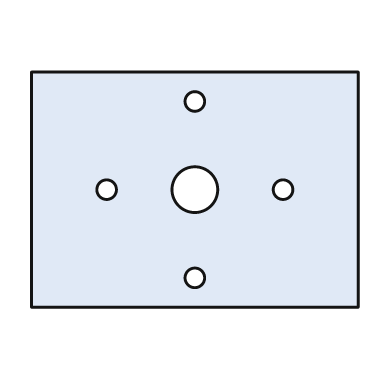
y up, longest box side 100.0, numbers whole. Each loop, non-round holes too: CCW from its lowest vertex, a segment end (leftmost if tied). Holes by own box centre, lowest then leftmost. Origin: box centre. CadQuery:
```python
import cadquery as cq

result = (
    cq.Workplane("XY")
    .moveTo(-50.0, -36.0)
    .lineTo(50.0, -36.0)
    .lineTo(50.0, 36.0)
    .lineTo(-50.0, 36.0)
    .close()
    .moveTo(0.0, -27.0)
    .circle(3.0)
    .moveTo(-27.0, 0.0)
    .circle(3.0)
    .moveTo(0.0, 0.0)
    .circle(7.0)
    .moveTo(27.0, 0.0)
    .circle(3.0)
    .moveTo(0.0, 27.0)
    .circle(3.0)
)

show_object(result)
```